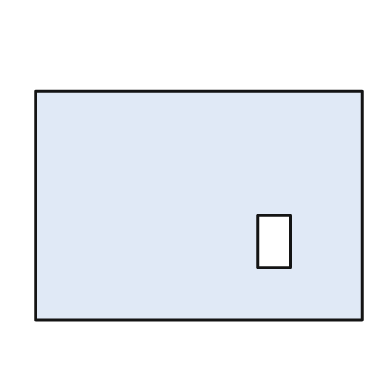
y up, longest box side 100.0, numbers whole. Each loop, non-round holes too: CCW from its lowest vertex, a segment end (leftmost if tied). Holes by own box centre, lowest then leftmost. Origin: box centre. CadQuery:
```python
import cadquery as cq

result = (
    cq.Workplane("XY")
    .moveTo(-50.0, -35.0)
    .lineTo(50.0, -35.0)
    .lineTo(50.0, 35.0)
    .lineTo(-50.0, 35.0)
    .close()
    .moveTo(18.0, -19.0)
    .lineTo(28.0, -19.0)
    .lineTo(28.0, -3.0)
    .lineTo(18.0, -3.0)
    .close()
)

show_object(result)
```